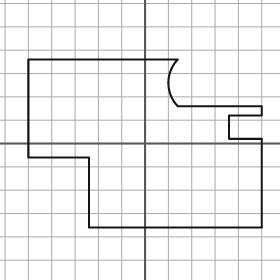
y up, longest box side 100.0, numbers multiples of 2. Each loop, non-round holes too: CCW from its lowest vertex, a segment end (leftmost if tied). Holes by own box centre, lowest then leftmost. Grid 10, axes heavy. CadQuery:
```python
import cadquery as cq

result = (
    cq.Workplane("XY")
    .moveTo(-24.0, -36.0)
    .lineTo(50.0, -36.0)
    .lineTo(50.0, 2.0)
    .lineTo(36.0, 2.0)
    .lineTo(36.0, 12.0)
    .lineTo(50.0, 12.0)
    .lineTo(50.0, 16.0)
    .lineTo(14.0, 16.0)
    .threePointArc((10.0, 26.0), (14.0, 36.0))
    .lineTo(-50.0, 36.0)
    .lineTo(-50.0, -6.0)
    .lineTo(-24.0, -6.0)
    .close()
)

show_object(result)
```